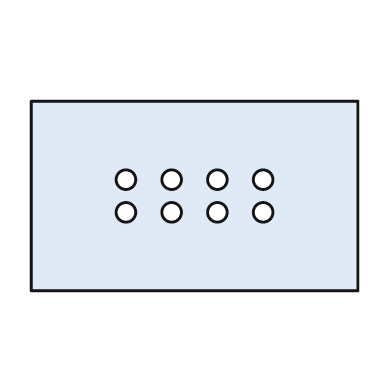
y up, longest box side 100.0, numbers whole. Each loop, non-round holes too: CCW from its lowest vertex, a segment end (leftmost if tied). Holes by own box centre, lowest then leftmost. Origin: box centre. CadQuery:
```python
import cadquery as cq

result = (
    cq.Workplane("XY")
    .moveTo(-50.0, -29.0)
    .lineTo(50.0, -29.0)
    .lineTo(50.0, 29.0)
    .lineTo(-50.0, 29.0)
    .close()
    .moveTo(-21.0, -5.0)
    .circle(3.0)
    .moveTo(-7.0, -5.0)
    .circle(3.0)
    .moveTo(7.0, -5.0)
    .circle(3.0)
    .moveTo(21.0, -5.0)
    .circle(3.0)
    .moveTo(-21.0, 5.0)
    .circle(3.0)
    .moveTo(-7.0, 5.0)
    .circle(3.0)
    .moveTo(7.0, 5.0)
    .circle(3.0)
    .moveTo(21.0, 5.0)
    .circle(3.0)
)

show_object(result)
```